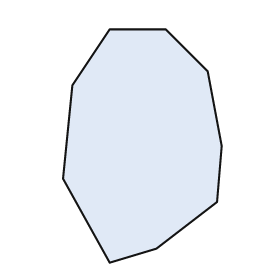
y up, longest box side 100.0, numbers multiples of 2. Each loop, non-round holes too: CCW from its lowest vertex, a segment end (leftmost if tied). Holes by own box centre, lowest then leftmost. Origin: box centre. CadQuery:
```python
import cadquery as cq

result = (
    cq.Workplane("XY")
    .moveTo(-14.0, -50.0)
    .lineTo(6.0, -44.0)
    .lineTo(32.0, -24.0)
    .lineTo(34.0, 0.0)
    .lineTo(28.0, 32.0)
    .lineTo(10.0, 50.0)
    .lineTo(-14.0, 50.0)
    .lineTo(-30.0, 26.0)
    .lineTo(-34.0, -14.0)
    .close()
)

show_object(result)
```